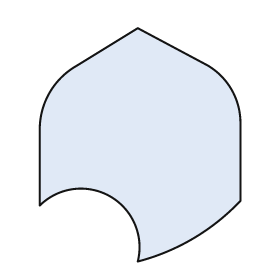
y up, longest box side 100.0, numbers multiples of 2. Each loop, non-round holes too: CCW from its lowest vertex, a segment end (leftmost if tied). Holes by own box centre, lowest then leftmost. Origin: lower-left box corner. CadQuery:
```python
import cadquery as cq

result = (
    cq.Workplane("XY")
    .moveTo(42.0, 0.0)
    .threePointArc((66.0, 10.0), (86.0, 26.0))
    .lineTo(86.0, 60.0)
    .threePointArc((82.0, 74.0), (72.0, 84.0))
    .lineTo(42.0, 100.0)
    .lineTo(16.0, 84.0)
    .threePointArc((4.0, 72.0), (0.0, 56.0))
    .lineTo(0.0, 24.0)
    .threePointArc((30.0, 28.0), (42.0, 0.0))
    .close()
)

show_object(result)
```